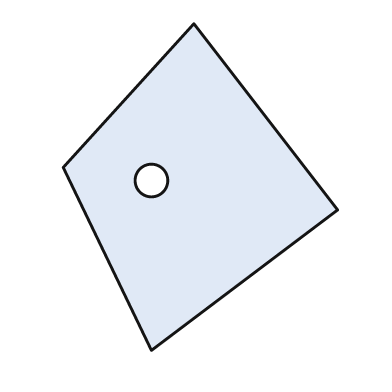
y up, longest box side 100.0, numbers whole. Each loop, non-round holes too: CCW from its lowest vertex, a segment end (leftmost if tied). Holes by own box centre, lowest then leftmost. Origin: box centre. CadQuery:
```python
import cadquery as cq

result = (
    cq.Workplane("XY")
    .moveTo(-15.0, -50.0)
    .lineTo(42.0, -7.0)
    .lineTo(-2.0, 50.0)
    .lineTo(-42.0, 6.0)
    .close()
    .moveTo(-15.0, 2.0)
    .circle(5.0)
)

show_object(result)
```